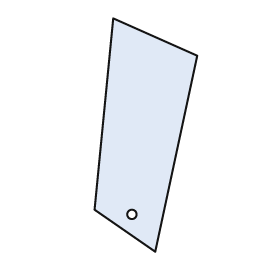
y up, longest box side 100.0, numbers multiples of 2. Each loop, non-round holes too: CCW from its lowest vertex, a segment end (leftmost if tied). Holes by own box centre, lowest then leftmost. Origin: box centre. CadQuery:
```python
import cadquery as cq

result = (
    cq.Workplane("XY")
    .moveTo(4.0, -50.0)
    .lineTo(22.0, 34.0)
    .lineTo(-14.0, 50.0)
    .lineTo(-22.0, -32.0)
    .close()
    .moveTo(-6.0, -34.0)
    .circle(2.0)
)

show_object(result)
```